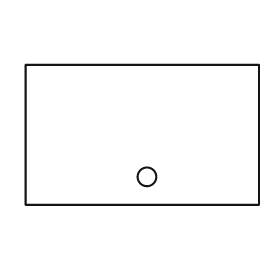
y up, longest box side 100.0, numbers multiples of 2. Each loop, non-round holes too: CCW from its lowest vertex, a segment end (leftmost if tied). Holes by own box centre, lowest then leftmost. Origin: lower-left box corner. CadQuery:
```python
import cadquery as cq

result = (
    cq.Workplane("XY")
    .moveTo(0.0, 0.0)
    .lineTo(100.0, 0.0)
    .lineTo(100.0, 60.0)
    .lineTo(0.0, 60.0)
    .close()
    .moveTo(52.0, 12.0)
    .circle(4.0)
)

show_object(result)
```